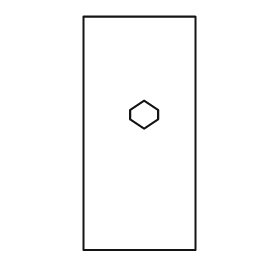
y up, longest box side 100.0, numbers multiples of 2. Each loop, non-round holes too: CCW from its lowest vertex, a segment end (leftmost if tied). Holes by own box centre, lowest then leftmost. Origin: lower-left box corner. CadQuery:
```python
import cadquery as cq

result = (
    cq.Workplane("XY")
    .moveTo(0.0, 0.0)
    .lineTo(48.0, 0.0)
    .lineTo(48.0, 100.0)
    .lineTo(0.0, 100.0)
    .close()
    .moveTo(26.0, 52.0)
    .lineTo(32.0, 56.0)
    .lineTo(32.0, 60.0)
    .lineTo(26.0, 64.0)
    .lineTo(20.0, 60.0)
    .lineTo(20.0, 56.0)
    .close()
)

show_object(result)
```